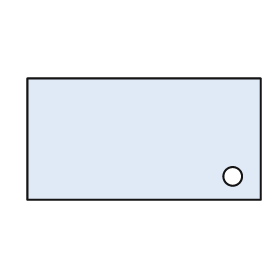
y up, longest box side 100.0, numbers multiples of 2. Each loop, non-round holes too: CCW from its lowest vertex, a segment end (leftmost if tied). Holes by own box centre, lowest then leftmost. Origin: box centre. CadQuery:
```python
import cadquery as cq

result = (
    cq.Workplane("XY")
    .moveTo(-50.0, -26.0)
    .lineTo(50.0, -26.0)
    .lineTo(50.0, 26.0)
    .lineTo(-50.0, 26.0)
    .close()
    .moveTo(38.0, -16.0)
    .circle(4.0)
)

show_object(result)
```